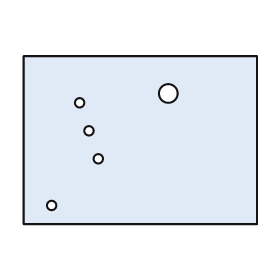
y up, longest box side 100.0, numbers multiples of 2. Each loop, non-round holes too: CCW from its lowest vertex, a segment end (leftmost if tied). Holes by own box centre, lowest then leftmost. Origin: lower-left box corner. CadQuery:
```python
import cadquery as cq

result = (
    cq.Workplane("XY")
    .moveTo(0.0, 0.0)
    .lineTo(100.0, 0.0)
    .lineTo(100.0, 72.0)
    .lineTo(0.0, 72.0)
    .close()
    .moveTo(12.0, 8.0)
    .circle(2.0)
    .moveTo(32.0, 28.0)
    .circle(2.0)
    .moveTo(28.0, 40.0)
    .circle(2.0)
    .moveTo(24.0, 52.0)
    .circle(2.0)
    .moveTo(62.0, 56.0)
    .circle(4.0)
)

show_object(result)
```